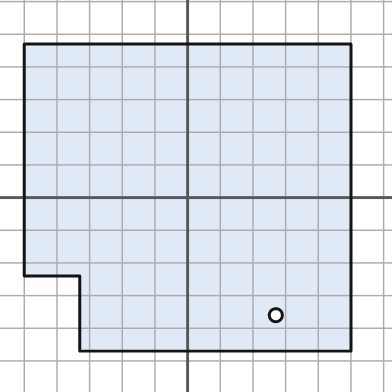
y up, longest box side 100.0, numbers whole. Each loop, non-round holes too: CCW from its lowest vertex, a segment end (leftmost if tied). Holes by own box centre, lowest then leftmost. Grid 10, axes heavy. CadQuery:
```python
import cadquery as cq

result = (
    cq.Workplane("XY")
    .moveTo(-33.0, -47.0)
    .lineTo(50.0, -47.0)
    .lineTo(50.0, 47.0)
    .lineTo(-50.0, 47.0)
    .lineTo(-50.0, -24.0)
    .lineTo(-33.0, -24.0)
    .close()
    .moveTo(27.0, -36.0)
    .circle(2.0)
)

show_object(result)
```